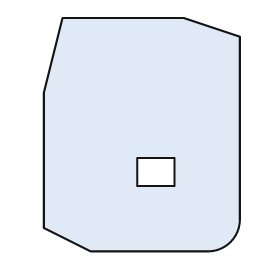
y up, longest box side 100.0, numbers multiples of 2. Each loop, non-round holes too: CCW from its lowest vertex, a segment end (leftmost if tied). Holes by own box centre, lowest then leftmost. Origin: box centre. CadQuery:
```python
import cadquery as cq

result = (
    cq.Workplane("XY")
    .moveTo(-22.0, -50.0)
    .lineTo(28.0, -50.0)
    .threePointArc((38.0, -46.0), (42.0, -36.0))
    .lineTo(42.0, 42.0)
    .lineTo(18.0, 50.0)
    .lineTo(-34.0, 50.0)
    .lineTo(-42.0, 18.0)
    .lineTo(-42.0, -40.0)
    .close()
    .moveTo(-2.0, -22.0)
    .lineTo(14.0, -22.0)
    .lineTo(14.0, -10.0)
    .lineTo(-2.0, -10.0)
    .close()
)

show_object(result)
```